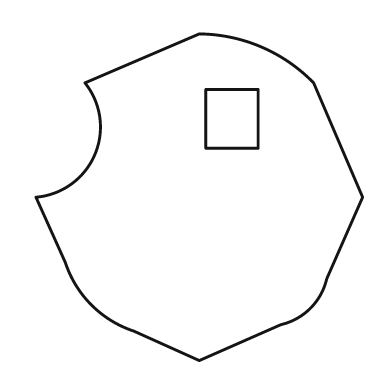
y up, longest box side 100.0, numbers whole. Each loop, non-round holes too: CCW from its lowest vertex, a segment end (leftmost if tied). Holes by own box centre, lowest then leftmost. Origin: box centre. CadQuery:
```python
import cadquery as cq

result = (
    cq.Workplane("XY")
    .moveTo(0.0, -50.0)
    .lineTo(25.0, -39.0)
    .threePointArc((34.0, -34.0), (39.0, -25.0))
    .lineTo(50.0, 0.0)
    .lineTo(35.0, 35.0)
    .threePointArc((19.0, 46.0), (0.0, 50.0))
    .lineTo(-35.0, 35.0)
    .threePointArc((-32.0, 13.0), (-50.0, 0.0))
    .lineTo(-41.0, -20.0)
    .threePointArc((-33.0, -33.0), (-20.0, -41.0))
    .close()
    .moveTo(2.0, 15.0)
    .lineTo(18.0, 15.0)
    .lineTo(18.0, 33.0)
    .lineTo(2.0, 33.0)
    .close()
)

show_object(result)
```